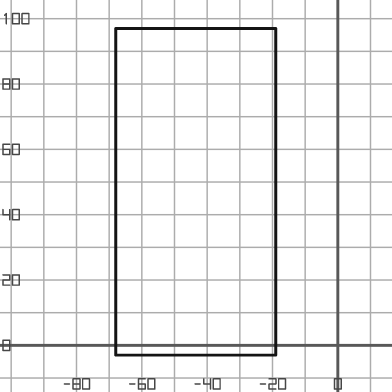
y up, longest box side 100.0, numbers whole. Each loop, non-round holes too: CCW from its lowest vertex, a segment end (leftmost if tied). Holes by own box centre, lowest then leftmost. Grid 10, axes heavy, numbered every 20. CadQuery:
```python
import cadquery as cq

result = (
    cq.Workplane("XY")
    .moveTo(-68.0, -3.0)
    .lineTo(-19.0, -3.0)
    .lineTo(-19.0, 97.0)
    .lineTo(-68.0, 97.0)
    .close()
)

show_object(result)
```